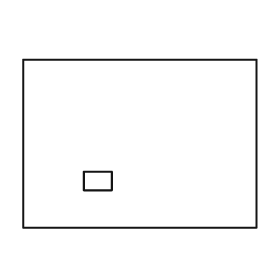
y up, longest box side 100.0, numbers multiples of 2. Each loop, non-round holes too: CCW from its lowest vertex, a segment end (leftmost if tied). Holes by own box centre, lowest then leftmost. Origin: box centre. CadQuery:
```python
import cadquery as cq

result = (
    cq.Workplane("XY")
    .moveTo(-50.0, -36.0)
    .lineTo(50.0, -36.0)
    .lineTo(50.0, 36.0)
    .lineTo(-50.0, 36.0)
    .close()
    .moveTo(-24.0, -20.0)
    .lineTo(-12.0, -20.0)
    .lineTo(-12.0, -12.0)
    .lineTo(-24.0, -12.0)
    .close()
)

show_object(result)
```